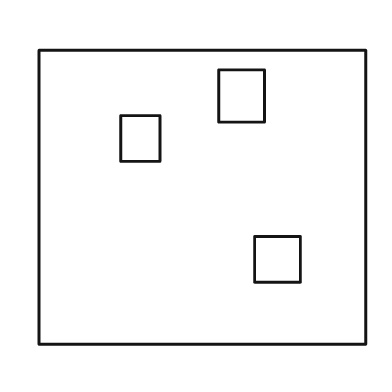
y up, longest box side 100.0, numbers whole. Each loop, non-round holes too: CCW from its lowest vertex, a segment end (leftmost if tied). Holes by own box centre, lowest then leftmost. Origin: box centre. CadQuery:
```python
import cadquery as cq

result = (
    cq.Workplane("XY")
    .moveTo(-50.0, -45.0)
    .lineTo(50.0, -45.0)
    .lineTo(50.0, 45.0)
    .lineTo(-50.0, 45.0)
    .close()
    .moveTo(16.0, -26.0)
    .lineTo(30.0, -26.0)
    .lineTo(30.0, -12.0)
    .lineTo(16.0, -12.0)
    .close()
    .moveTo(-25.0, 11.0)
    .lineTo(-13.0, 11.0)
    .lineTo(-13.0, 25.0)
    .lineTo(-25.0, 25.0)
    .close()
    .moveTo(5.0, 23.0)
    .lineTo(19.0, 23.0)
    .lineTo(19.0, 39.0)
    .lineTo(5.0, 39.0)
    .close()
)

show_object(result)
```